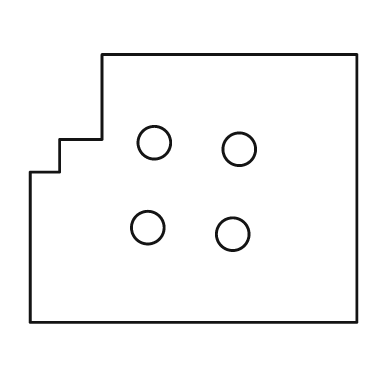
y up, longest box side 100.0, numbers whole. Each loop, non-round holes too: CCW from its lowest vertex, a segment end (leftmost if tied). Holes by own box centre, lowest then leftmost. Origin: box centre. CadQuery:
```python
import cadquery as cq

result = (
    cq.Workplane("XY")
    .moveTo(-50.0, -41.0)
    .lineTo(50.0, -41.0)
    .lineTo(50.0, 41.0)
    .lineTo(-28.0, 41.0)
    .lineTo(-28.0, 15.0)
    .lineTo(-41.0, 15.0)
    .lineTo(-41.0, 5.0)
    .lineTo(-50.0, 5.0)
    .close()
    .moveTo(12.0, -14.0)
    .circle(5.0)
    .moveTo(-14.0, -12.0)
    .circle(5.0)
    .moveTo(14.0, 12.0)
    .circle(5.0)
    .moveTo(-12.0, 14.0)
    .circle(5.0)
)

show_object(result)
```